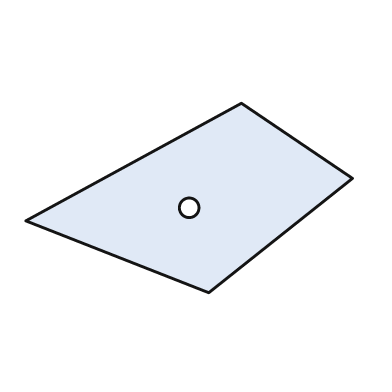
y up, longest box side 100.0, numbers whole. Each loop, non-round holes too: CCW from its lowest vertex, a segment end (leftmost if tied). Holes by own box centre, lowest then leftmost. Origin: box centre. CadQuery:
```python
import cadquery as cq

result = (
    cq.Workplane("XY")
    .moveTo(6.0, -29.0)
    .lineTo(50.0, 6.0)
    .lineTo(16.0, 29.0)
    .lineTo(-50.0, -7.0)
    .close()
    .moveTo(0.0, -3.0)
    .circle(3.0)
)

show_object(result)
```